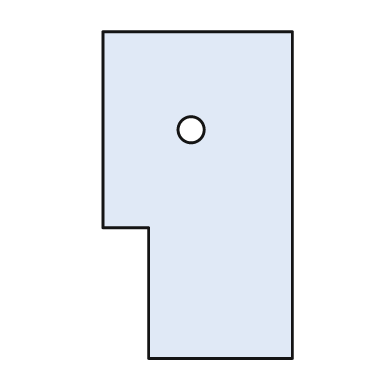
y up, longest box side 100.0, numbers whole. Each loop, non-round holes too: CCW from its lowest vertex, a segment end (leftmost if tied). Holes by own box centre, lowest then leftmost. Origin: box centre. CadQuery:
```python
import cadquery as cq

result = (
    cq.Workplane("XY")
    .moveTo(-15.0, -50.0)
    .lineTo(29.0, -50.0)
    .lineTo(29.0, 50.0)
    .lineTo(-29.0, 50.0)
    .lineTo(-29.0, -10.0)
    .lineTo(-15.0, -10.0)
    .close()
    .moveTo(-2.0, 20.0)
    .circle(4.0)
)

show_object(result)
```